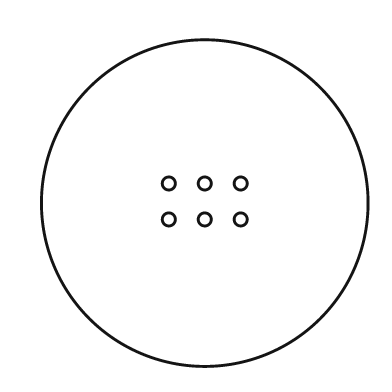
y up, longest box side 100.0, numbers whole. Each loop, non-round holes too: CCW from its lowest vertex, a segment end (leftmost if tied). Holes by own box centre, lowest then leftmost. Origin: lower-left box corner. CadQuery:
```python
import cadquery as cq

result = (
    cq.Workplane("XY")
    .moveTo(50.0, 50.0)
    .circle(50.0)
    .moveTo(39.0, 45.0)
    .circle(2.0)
    .moveTo(50.0, 45.0)
    .circle(2.0)
    .moveTo(61.0, 45.0)
    .circle(2.0)
    .moveTo(39.0, 56.0)
    .circle(2.0)
    .moveTo(50.0, 56.0)
    .circle(2.0)
    .moveTo(61.0, 56.0)
    .circle(2.0)
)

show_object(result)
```